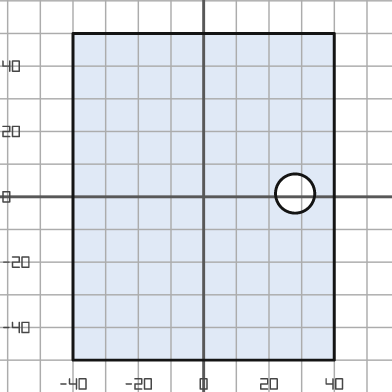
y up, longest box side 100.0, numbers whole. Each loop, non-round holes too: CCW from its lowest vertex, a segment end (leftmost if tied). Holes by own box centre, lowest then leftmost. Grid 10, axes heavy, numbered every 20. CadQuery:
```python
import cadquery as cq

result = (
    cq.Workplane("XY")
    .moveTo(-40.0, -50.0)
    .lineTo(40.0, -50.0)
    .lineTo(40.0, 50.0)
    .lineTo(-40.0, 50.0)
    .close()
    .moveTo(28.0, 1.0)
    .circle(6.0)
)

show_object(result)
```